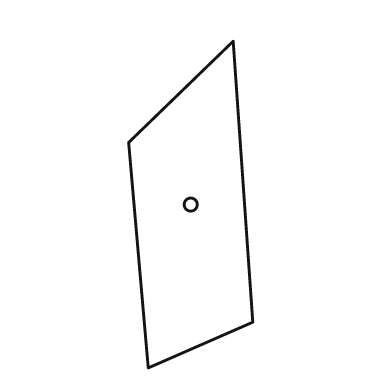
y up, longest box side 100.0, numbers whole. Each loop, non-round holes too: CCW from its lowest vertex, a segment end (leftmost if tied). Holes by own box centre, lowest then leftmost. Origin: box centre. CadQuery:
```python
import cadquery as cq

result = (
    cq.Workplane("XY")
    .moveTo(-13.0, -50.0)
    .lineTo(19.0, -36.0)
    .lineTo(13.0, 50.0)
    .lineTo(-19.0, 19.0)
    .close()
    .moveTo(0.0, 0.0)
    .circle(2.0)
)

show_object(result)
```